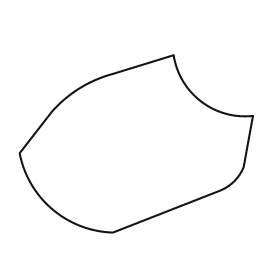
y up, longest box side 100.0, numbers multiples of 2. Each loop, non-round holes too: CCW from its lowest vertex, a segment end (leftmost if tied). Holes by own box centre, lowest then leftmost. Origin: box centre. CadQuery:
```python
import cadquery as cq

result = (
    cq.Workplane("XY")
    .moveTo(-10.0, -38.0)
    .lineTo(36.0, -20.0)
    .threePointArc((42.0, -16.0), (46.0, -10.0))
    .lineTo(50.0, 12.0)
    .threePointArc((28.0, 18.0), (16.0, 38.0))
    .lineTo(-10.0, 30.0)
    .threePointArc((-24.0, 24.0), (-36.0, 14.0))
    .lineTo(-50.0, -4.0)
    .threePointArc((-36.0, -28.0), (-10.0, -38.0))
    .close()
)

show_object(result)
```